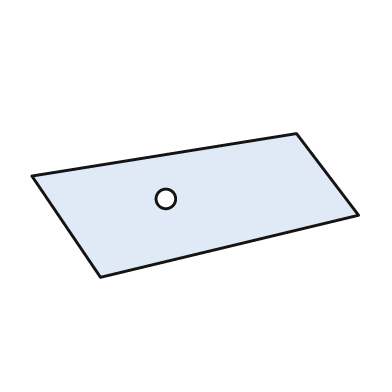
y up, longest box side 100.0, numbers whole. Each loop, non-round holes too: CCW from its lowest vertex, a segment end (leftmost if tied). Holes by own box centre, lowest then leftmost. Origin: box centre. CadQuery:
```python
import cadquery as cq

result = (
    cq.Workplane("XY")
    .moveTo(-29.0, -22.0)
    .lineTo(50.0, -3.0)
    .lineTo(31.0, 22.0)
    .lineTo(-50.0, 9.0)
    .close()
    .moveTo(-9.0, 2.0)
    .circle(3.0)
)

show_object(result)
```